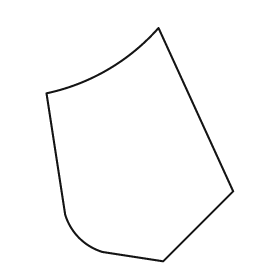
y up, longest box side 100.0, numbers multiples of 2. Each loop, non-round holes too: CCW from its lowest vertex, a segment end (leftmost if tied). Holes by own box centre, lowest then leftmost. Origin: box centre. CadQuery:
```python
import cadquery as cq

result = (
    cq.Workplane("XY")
    .moveTo(10.0, -50.0)
    .lineTo(40.0, -20.0)
    .lineTo(8.0, 50.0)
    .threePointArc((-14.0, 32.0), (-40.0, 22.0))
    .lineTo(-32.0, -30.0)
    .threePointArc((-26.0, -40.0), (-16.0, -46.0))
    .close()
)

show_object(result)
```